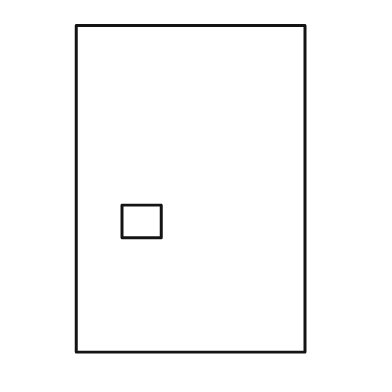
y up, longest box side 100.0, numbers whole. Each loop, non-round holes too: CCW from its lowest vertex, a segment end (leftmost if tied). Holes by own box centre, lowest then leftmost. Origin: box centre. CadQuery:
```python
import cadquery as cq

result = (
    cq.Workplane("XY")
    .moveTo(-35.0, -50.0)
    .lineTo(35.0, -50.0)
    .lineTo(35.0, 50.0)
    .lineTo(-35.0, 50.0)
    .close()
    .moveTo(-21.0, -15.0)
    .lineTo(-9.0, -15.0)
    .lineTo(-9.0, -5.0)
    .lineTo(-21.0, -5.0)
    .close()
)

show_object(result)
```